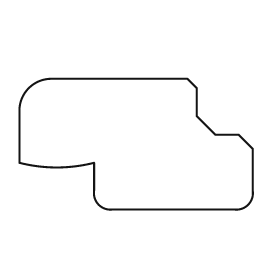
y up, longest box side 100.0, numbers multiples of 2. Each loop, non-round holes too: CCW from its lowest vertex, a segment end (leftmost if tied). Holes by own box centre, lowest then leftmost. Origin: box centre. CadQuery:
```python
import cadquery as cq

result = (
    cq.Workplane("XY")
    .moveTo(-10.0, -28.0)
    .lineTo(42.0, -28.0)
    .threePointArc((48.0, -26.0), (50.0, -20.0))
    .lineTo(50.0, -2.0)
    .lineTo(44.0, 4.0)
    .lineTo(34.0, 4.0)
    .lineTo(26.0, 12.0)
    .lineTo(26.0, 24.0)
    .lineTo(22.0, 28.0)
    .lineTo(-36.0, 28.0)
    .threePointArc((-46.0, 24.0), (-50.0, 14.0))
    .lineTo(-50.0, -8.0)
    .threePointArc((-34.0, -10.0), (-18.0, -8.0))
    .lineTo(-18.0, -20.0)
    .threePointArc((-16.0, -26.0), (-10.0, -28.0))
    .close()
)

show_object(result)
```